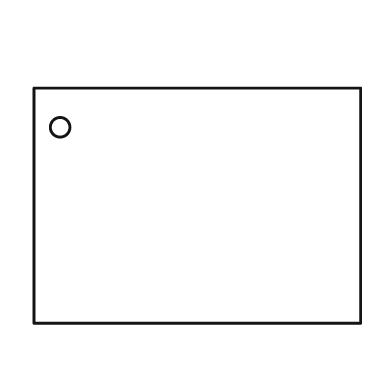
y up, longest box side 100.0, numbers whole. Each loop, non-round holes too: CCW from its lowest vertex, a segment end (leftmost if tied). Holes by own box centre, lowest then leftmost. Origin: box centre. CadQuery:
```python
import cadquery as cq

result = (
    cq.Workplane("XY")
    .moveTo(-50.0, -36.0)
    .lineTo(50.0, -36.0)
    .lineTo(50.0, 36.0)
    .lineTo(-50.0, 36.0)
    .close()
    .moveTo(-42.0, 24.0)
    .circle(3.0)
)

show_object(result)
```